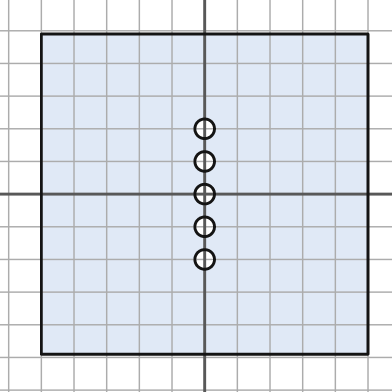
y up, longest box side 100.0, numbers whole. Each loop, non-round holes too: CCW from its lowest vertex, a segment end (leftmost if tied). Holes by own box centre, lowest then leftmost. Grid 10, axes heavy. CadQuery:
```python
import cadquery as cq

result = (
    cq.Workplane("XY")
    .moveTo(-50.0, -49.0)
    .lineTo(50.0, -49.0)
    .lineTo(50.0, 49.0)
    .lineTo(-50.0, 49.0)
    .close()
    .moveTo(0.0, -20.0)
    .circle(3.0)
    .moveTo(0.0, -10.0)
    .circle(3.0)
    .moveTo(0.0, 0.0)
    .circle(3.0)
    .moveTo(0.0, 10.0)
    .circle(3.0)
    .moveTo(0.0, 20.0)
    .circle(3.0)
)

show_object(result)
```